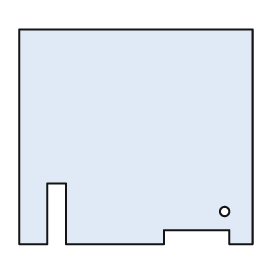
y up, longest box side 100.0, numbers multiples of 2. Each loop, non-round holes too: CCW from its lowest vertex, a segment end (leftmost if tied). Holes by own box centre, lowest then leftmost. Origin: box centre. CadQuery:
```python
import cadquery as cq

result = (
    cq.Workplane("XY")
    .moveTo(-50.0, -46.0)
    .lineTo(-38.0, -46.0)
    .lineTo(-38.0, -20.0)
    .lineTo(-30.0, -20.0)
    .lineTo(-30.0, -46.0)
    .lineTo(12.0, -46.0)
    .lineTo(12.0, -40.0)
    .lineTo(40.0, -40.0)
    .lineTo(40.0, -46.0)
    .lineTo(50.0, -46.0)
    .lineTo(50.0, 46.0)
    .lineTo(-50.0, 46.0)
    .close()
    .moveTo(38.0, -32.0)
    .circle(2.0)
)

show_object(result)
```